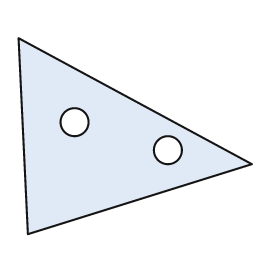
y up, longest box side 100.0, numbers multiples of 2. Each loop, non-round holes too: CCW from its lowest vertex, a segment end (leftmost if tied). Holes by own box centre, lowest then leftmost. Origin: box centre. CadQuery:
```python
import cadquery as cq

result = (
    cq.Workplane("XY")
    .moveTo(-46.0, -42.0)
    .lineTo(50.0, -12.0)
    .lineTo(-50.0, 42.0)
    .close()
    .moveTo(14.0, -6.0)
    .circle(6.0)
    .moveTo(-26.0, 6.0)
    .circle(6.0)
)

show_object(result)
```